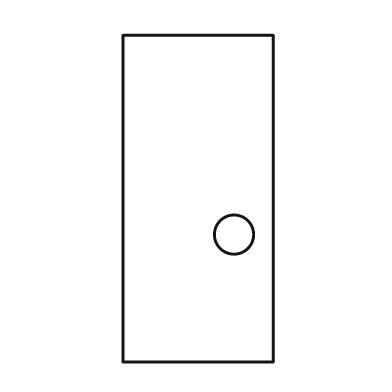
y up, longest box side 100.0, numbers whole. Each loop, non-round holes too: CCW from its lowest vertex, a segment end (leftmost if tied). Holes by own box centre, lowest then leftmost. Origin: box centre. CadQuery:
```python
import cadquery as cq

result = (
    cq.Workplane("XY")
    .moveTo(-23.0, -50.0)
    .lineTo(23.0, -50.0)
    .lineTo(23.0, 50.0)
    .lineTo(-23.0, 50.0)
    .close()
    .moveTo(11.0, -11.0)
    .circle(6.0)
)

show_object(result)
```